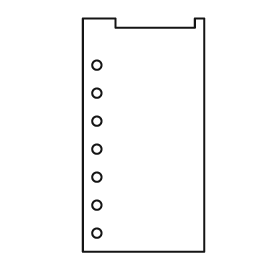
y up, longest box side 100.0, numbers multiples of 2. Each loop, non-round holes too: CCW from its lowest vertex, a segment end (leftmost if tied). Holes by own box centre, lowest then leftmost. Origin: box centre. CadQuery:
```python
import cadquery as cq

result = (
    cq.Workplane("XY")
    .moveTo(-26.0, -50.0)
    .lineTo(26.0, -50.0)
    .lineTo(26.0, 50.0)
    .lineTo(22.0, 50.0)
    .lineTo(22.0, 46.0)
    .lineTo(-12.0, 46.0)
    .lineTo(-12.0, 50.0)
    .lineTo(-26.0, 50.0)
    .close()
    .moveTo(-20.0, -42.0)
    .circle(2.0)
    .moveTo(-20.0, -30.0)
    .circle(2.0)
    .moveTo(-20.0, -18.0)
    .circle(2.0)
    .moveTo(-20.0, -6.0)
    .circle(2.0)
    .moveTo(-20.0, 6.0)
    .circle(2.0)
    .moveTo(-20.0, 18.0)
    .circle(2.0)
    .moveTo(-20.0, 30.0)
    .circle(2.0)
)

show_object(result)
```